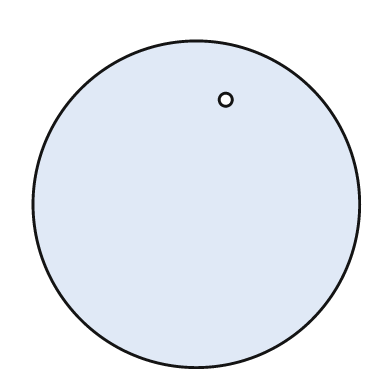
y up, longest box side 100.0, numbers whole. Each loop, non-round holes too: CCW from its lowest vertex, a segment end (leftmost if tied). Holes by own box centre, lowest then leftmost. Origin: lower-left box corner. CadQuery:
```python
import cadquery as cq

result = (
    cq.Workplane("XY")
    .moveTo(50.0, 50.0)
    .circle(50.0)
    .moveTo(59.0, 82.0)
    .circle(2.0)
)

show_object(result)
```